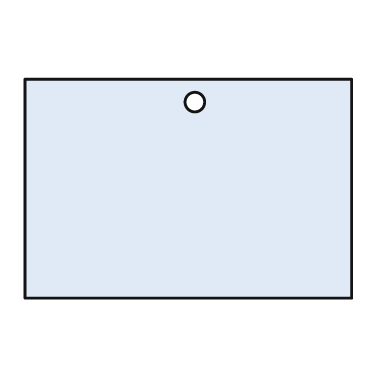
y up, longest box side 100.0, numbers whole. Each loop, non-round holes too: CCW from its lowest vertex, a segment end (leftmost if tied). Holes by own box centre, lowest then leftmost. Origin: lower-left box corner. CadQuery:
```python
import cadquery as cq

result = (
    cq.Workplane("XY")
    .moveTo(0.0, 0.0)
    .lineTo(100.0, 0.0)
    .lineTo(100.0, 67.0)
    .lineTo(0.0, 67.0)
    .close()
    .moveTo(52.0, 60.0)
    .circle(3.0)
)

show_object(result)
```